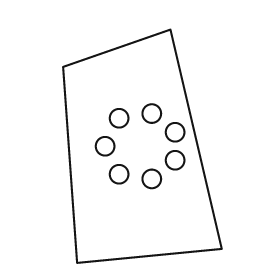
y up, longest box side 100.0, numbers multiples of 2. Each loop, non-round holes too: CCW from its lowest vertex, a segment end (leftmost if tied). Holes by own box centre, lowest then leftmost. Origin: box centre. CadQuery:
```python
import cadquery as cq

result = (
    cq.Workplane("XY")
    .moveTo(-28.0, -50.0)
    .lineTo(34.0, -44.0)
    .lineTo(12.0, 50.0)
    .lineTo(-34.0, 34.0)
    .close()
    .moveTo(4.0, -14.0)
    .circle(4.0)
    .moveTo(-10.0, -12.0)
    .circle(4.0)
    .moveTo(14.0, -6.0)
    .circle(4.0)
    .moveTo(-16.0, 0.0)
    .circle(4.0)
    .moveTo(14.0, 6.0)
    .circle(4.0)
    .moveTo(-10.0, 12.0)
    .circle(4.0)
    .moveTo(4.0, 14.0)
    .circle(4.0)
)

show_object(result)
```